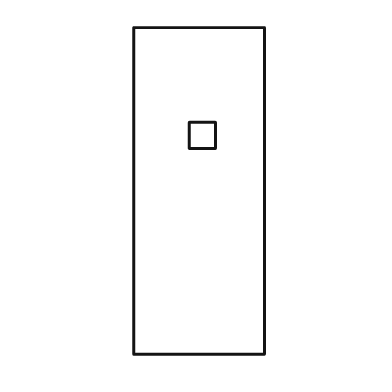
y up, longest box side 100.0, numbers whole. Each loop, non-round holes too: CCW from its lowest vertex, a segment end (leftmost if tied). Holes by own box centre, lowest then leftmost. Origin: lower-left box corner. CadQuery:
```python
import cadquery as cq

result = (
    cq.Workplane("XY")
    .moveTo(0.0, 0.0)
    .lineTo(40.0, 0.0)
    .lineTo(40.0, 100.0)
    .lineTo(0.0, 100.0)
    .close()
    .moveTo(17.0, 63.0)
    .lineTo(25.0, 63.0)
    .lineTo(25.0, 71.0)
    .lineTo(17.0, 71.0)
    .close()
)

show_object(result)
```